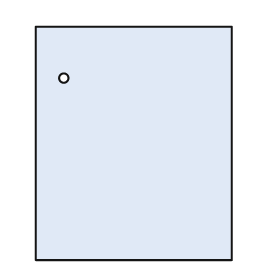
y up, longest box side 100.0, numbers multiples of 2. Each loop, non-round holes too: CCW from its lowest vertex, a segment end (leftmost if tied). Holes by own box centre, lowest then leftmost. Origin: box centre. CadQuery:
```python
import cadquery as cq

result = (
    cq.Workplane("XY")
    .moveTo(-42.0, -50.0)
    .lineTo(42.0, -50.0)
    .lineTo(42.0, 50.0)
    .lineTo(-42.0, 50.0)
    .close()
    .moveTo(-30.0, 28.0)
    .circle(2.0)
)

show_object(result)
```